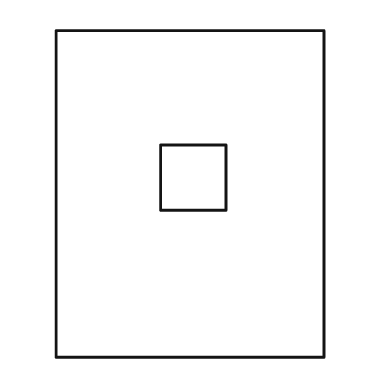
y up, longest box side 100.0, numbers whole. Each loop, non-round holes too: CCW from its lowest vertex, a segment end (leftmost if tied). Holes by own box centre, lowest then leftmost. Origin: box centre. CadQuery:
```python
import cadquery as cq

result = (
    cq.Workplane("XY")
    .moveTo(-41.0, -50.0)
    .lineTo(41.0, -50.0)
    .lineTo(41.0, 50.0)
    .lineTo(-41.0, 50.0)
    .close()
    .moveTo(-9.0, -5.0)
    .lineTo(11.0, -5.0)
    .lineTo(11.0, 15.0)
    .lineTo(-9.0, 15.0)
    .close()
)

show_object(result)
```